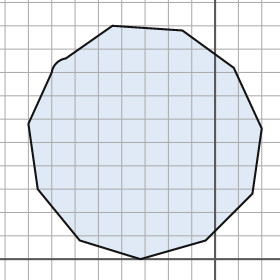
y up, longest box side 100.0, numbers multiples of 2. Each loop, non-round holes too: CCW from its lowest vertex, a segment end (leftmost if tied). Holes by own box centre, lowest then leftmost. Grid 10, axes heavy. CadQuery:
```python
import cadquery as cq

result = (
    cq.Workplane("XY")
    .moveTo(-32.0, 0.0)
    .lineTo(-4.0, 8.0)
    .lineTo(16.0, 28.0)
    .lineTo(20.0, 56.0)
    .lineTo(8.0, 82.0)
    .lineTo(-14.0, 98.0)
    .lineTo(-44.0, 100.0)
    .lineTo(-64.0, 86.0)
    .threePointArc((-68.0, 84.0), (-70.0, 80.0))
    .lineTo(-80.0, 58.0)
    .lineTo(-76.0, 30.0)
    .lineTo(-58.0, 8.0)
    .close()
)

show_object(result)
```